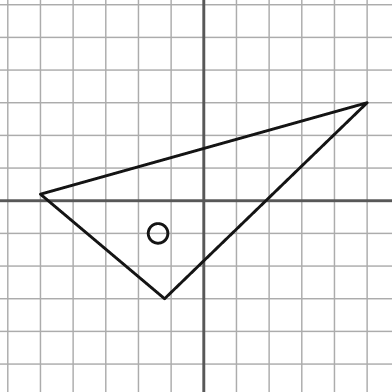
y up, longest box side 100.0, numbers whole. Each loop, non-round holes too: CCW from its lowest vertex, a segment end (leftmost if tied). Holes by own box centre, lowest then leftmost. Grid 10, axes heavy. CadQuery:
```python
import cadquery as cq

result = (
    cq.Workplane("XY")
    .moveTo(-12.0, -30.0)
    .lineTo(50.0, 30.0)
    .lineTo(-50.0, 2.0)
    .close()
    .moveTo(-14.0, -10.0)
    .circle(3.0)
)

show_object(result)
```